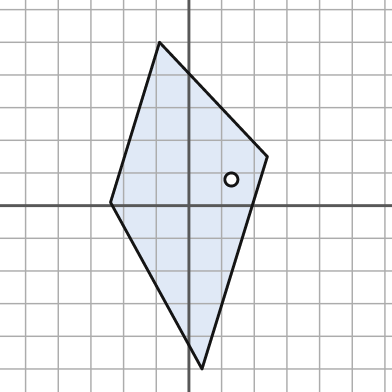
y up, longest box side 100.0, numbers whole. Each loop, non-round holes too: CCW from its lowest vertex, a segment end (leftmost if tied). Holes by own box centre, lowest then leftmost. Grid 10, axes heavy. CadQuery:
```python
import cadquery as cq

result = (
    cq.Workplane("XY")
    .moveTo(4.0, -50.0)
    .lineTo(24.0, 15.0)
    .lineTo(-9.0, 50.0)
    .lineTo(-24.0, 1.0)
    .close()
    .moveTo(13.0, 8.0)
    .circle(2.0)
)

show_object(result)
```